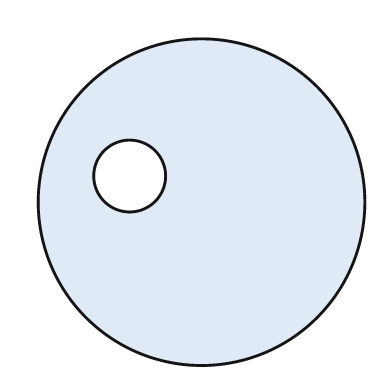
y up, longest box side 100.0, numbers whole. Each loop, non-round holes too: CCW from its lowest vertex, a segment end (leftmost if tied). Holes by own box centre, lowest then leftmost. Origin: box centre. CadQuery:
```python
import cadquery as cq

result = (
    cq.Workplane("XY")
    .moveTo(0.0, 0.0)
    .circle(50.0)
    .moveTo(-22.0, 8.0)
    .circle(11.0)
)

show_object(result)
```